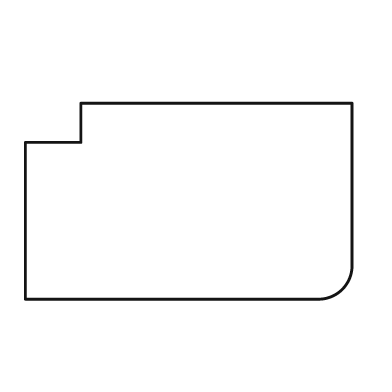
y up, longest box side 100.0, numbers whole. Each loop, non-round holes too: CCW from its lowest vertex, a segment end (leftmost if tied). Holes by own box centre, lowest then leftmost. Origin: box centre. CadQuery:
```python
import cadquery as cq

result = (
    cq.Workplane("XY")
    .moveTo(-50.0, -30.0)
    .lineTo(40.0, -30.0)
    .threePointArc((47.0, -27.0), (50.0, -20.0))
    .lineTo(50.0, 30.0)
    .lineTo(-33.0, 30.0)
    .lineTo(-33.0, 18.0)
    .lineTo(-50.0, 18.0)
    .close()
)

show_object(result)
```